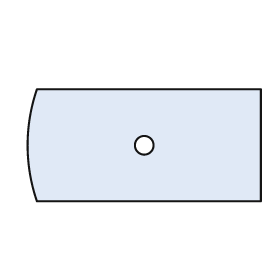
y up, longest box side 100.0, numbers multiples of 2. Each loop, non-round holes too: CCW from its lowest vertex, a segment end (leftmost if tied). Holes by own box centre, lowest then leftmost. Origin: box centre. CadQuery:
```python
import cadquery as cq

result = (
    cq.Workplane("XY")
    .moveTo(-46.0, -24.0)
    .lineTo(50.0, -24.0)
    .lineTo(50.0, 24.0)
    .lineTo(-46.0, 24.0)
    .threePointArc((-50.0, 0.0), (-46.0, -24.0))
    .close()
    .moveTo(0.0, 0.0)
    .circle(4.0)
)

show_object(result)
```